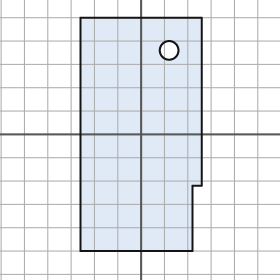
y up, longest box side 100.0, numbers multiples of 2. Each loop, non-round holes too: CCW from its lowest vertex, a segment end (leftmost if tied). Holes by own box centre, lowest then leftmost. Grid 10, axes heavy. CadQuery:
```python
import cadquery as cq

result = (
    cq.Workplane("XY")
    .moveTo(-26.0, -50.0)
    .lineTo(22.0, -50.0)
    .lineTo(22.0, -22.0)
    .lineTo(26.0, -22.0)
    .lineTo(26.0, 50.0)
    .lineTo(-26.0, 50.0)
    .close()
    .moveTo(12.0, 36.0)
    .circle(4.0)
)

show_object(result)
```